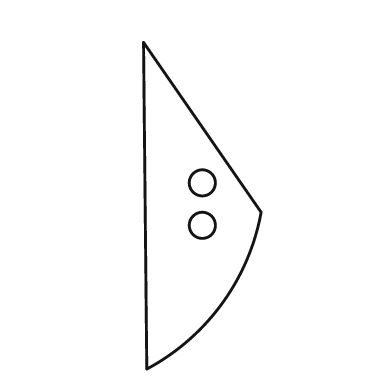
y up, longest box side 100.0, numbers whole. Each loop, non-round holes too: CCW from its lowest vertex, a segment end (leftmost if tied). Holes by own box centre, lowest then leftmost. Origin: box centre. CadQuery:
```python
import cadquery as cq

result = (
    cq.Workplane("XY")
    .moveTo(-17.0, -50.0)
    .threePointArc((6.0, -30.0), (18.0, -2.0))
    .lineTo(-18.0, 50.0)
    .close()
    .moveTo(0.0, -6.0)
    .circle(4.0)
    .moveTo(0.0, 7.0)
    .circle(4.0)
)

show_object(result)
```